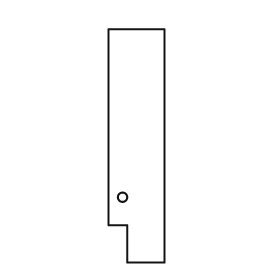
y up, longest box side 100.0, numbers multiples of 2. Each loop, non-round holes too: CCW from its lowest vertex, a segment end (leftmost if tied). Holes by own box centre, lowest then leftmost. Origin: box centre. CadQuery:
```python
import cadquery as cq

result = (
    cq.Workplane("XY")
    .moveTo(-4.0, -50.0)
    .lineTo(12.0, -50.0)
    .lineTo(12.0, 50.0)
    .lineTo(-12.0, 50.0)
    .lineTo(-12.0, -34.0)
    .lineTo(-4.0, -34.0)
    .close()
    .moveTo(-6.0, -22.0)
    .circle(2.0)
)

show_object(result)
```